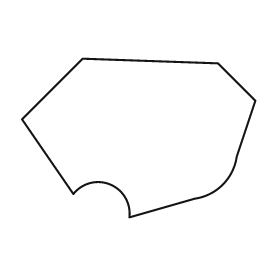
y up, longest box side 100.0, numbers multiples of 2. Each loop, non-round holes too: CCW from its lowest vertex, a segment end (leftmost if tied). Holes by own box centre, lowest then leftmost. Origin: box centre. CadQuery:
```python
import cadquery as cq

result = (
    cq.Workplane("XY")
    .moveTo(-4.0, -34.0)
    .lineTo(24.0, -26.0)
    .threePointArc((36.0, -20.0), (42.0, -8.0))
    .lineTo(50.0, 16.0)
    .lineTo(34.0, 32.0)
    .lineTo(-24.0, 34.0)
    .lineTo(-50.0, 8.0)
    .lineTo(-28.0, -24.0)
    .threePointArc((-12.0, -20.0), (-4.0, -34.0))
    .close()
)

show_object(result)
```